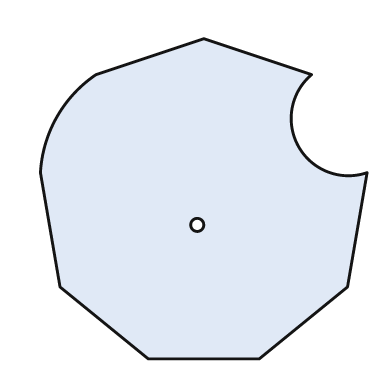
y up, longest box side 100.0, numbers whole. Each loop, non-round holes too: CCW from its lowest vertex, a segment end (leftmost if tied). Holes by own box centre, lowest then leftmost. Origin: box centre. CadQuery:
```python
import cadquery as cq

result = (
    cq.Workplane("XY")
    .moveTo(-17.0, -49.0)
    .lineTo(17.0, -49.0)
    .lineTo(44.0, -27.0)
    .lineTo(50.0, 8.0)
    .threePointArc((29.0, 16.0), (33.0, 38.0))
    .lineTo(0.0, 49.0)
    .lineTo(-33.0, 38.0)
    .threePointArc((-45.0, 25.0), (-50.0, 8.0))
    .lineTo(-44.0, -27.0)
    .close()
    .moveTo(-2.0, -8.0)
    .circle(2.0)
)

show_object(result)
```